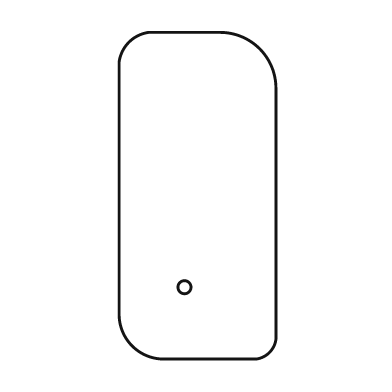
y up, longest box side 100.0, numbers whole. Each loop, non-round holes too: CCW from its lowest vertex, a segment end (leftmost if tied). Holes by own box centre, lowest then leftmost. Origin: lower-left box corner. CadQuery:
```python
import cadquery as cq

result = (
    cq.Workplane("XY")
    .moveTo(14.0, 0.0)
    .lineTo(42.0, 0.0)
    .threePointArc((46.0, 2.0), (48.0, 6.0))
    .lineTo(48.0, 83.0)
    .threePointArc((43.0, 95.0), (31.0, 100.0))
    .lineTo(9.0, 100.0)
    .threePointArc((3.0, 97.0), (0.0, 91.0))
    .lineTo(0.0, 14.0)
    .threePointArc((4.0, 4.0), (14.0, 0.0))
    .close()
    .moveTo(20.0, 22.0)
    .circle(2.0)
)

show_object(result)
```